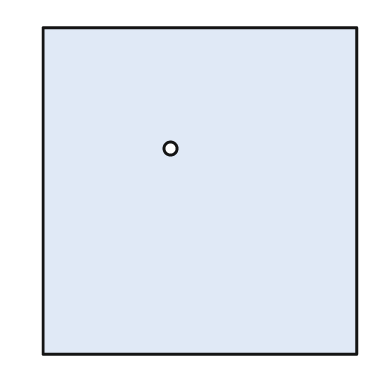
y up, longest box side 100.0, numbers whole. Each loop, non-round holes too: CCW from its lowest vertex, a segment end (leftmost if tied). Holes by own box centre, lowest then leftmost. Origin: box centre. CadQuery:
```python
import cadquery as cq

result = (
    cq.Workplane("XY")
    .moveTo(-48.0, -50.0)
    .lineTo(48.0, -50.0)
    .lineTo(48.0, 50.0)
    .lineTo(-48.0, 50.0)
    .close()
    .moveTo(-9.0, 13.0)
    .circle(2.0)
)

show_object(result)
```